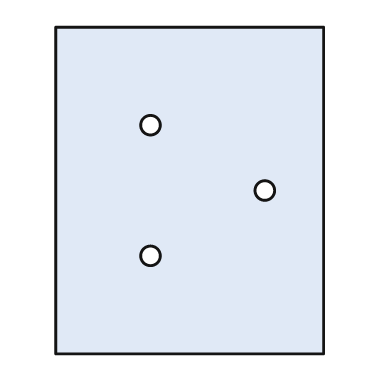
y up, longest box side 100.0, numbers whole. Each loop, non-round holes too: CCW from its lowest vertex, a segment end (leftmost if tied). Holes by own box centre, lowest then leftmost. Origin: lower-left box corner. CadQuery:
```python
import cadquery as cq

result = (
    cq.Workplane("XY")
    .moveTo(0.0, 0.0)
    .lineTo(82.0, 0.0)
    .lineTo(82.0, 100.0)
    .lineTo(0.0, 100.0)
    .close()
    .moveTo(29.0, 30.0)
    .circle(3.0)
    .moveTo(64.0, 50.0)
    .circle(3.0)
    .moveTo(29.0, 70.0)
    .circle(3.0)
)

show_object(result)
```